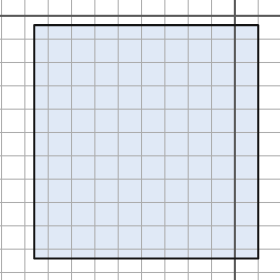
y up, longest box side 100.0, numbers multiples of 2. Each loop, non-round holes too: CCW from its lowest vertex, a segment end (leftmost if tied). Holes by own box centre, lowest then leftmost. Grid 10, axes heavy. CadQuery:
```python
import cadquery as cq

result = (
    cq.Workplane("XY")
    .moveTo(-86.0, -104.0)
    .lineTo(10.0, -104.0)
    .lineTo(10.0, -4.0)
    .lineTo(-86.0, -4.0)
    .close()
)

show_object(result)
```